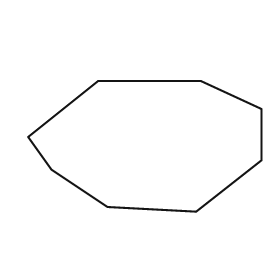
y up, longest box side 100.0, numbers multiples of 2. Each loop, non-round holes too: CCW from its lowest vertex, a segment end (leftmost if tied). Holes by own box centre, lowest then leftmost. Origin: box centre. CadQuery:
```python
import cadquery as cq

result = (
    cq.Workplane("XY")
    .moveTo(22.0, -28.0)
    .lineTo(50.0, -6.0)
    .lineTo(50.0, 16.0)
    .lineTo(24.0, 28.0)
    .lineTo(-20.0, 28.0)
    .lineTo(-50.0, 4.0)
    .lineTo(-40.0, -10.0)
    .lineTo(-16.0, -26.0)
    .close()
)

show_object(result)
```